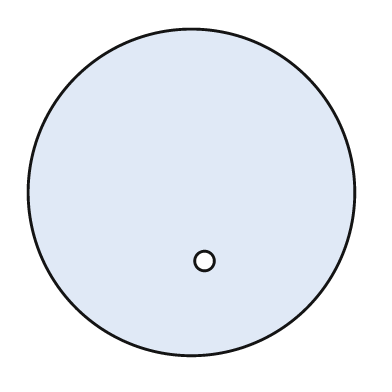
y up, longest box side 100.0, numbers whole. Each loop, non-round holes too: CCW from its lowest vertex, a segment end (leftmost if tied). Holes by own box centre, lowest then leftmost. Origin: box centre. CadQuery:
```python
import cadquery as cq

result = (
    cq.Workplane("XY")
    .moveTo(0.0, 0.0)
    .circle(50.0)
    .moveTo(4.0, -21.0)
    .circle(3.0)
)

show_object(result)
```